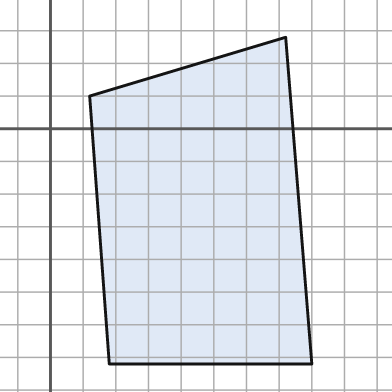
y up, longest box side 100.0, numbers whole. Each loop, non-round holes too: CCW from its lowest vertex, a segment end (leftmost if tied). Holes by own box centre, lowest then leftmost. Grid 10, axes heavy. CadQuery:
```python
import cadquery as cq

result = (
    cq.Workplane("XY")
    .moveTo(18.0, -72.0)
    .lineTo(80.0, -72.0)
    .lineTo(72.0, 28.0)
    .lineTo(12.0, 10.0)
    .close()
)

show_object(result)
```